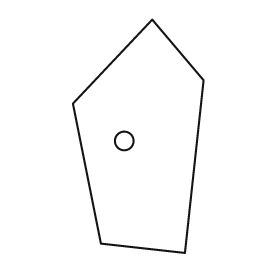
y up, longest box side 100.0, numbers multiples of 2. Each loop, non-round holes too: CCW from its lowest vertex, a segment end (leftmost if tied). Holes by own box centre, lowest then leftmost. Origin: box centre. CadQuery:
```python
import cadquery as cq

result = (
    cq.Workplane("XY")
    .moveTo(20.0, -50.0)
    .lineTo(28.0, 24.0)
    .lineTo(6.0, 50.0)
    .lineTo(-28.0, 14.0)
    .lineTo(-16.0, -46.0)
    .close()
    .moveTo(-6.0, -2.0)
    .circle(4.0)
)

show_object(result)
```